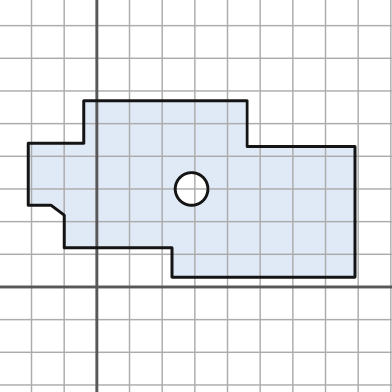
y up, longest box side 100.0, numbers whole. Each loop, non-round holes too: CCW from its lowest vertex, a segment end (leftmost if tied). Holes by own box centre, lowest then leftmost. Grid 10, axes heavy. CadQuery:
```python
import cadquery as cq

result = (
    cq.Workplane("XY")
    .moveTo(23.0, 3.0)
    .lineTo(79.0, 3.0)
    .lineTo(79.0, 43.0)
    .lineTo(46.0, 43.0)
    .lineTo(46.0, 57.0)
    .lineTo(-4.0, 57.0)
    .lineTo(-4.0, 44.0)
    .lineTo(-21.0, 44.0)
    .lineTo(-21.0, 25.0)
    .lineTo(-14.0, 25.0)
    .lineTo(-10.0, 22.0)
    .lineTo(-10.0, 12.0)
    .lineTo(23.0, 12.0)
    .close()
    .moveTo(29.0, 30.0)
    .circle(5.0)
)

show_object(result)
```